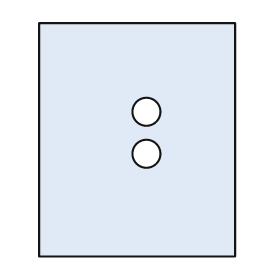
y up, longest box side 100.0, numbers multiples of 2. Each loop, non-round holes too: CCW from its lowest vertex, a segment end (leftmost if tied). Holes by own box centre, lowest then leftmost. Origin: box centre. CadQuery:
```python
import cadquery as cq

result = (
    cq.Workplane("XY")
    .moveTo(-42.0, -50.0)
    .lineTo(42.0, -50.0)
    .lineTo(42.0, 50.0)
    .lineTo(-42.0, 50.0)
    .close()
    .moveTo(4.0, -6.0)
    .circle(6.0)
    .moveTo(4.0, 12.0)
    .circle(6.0)
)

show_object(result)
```